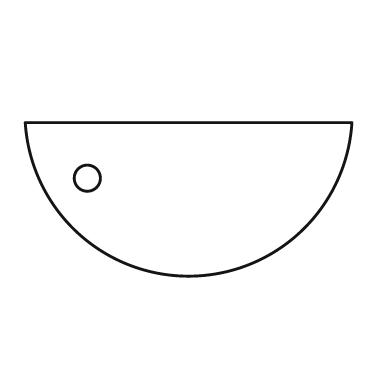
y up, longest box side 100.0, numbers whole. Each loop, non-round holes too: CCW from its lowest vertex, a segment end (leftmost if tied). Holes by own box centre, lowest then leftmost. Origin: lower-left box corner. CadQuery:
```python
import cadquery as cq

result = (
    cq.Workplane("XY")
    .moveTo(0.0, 47.0)
    .threePointArc((50.0, 0.0), (100.0, 47.0))
    .close()
    .moveTo(19.0, 30.0)
    .circle(4.0)
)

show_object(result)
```